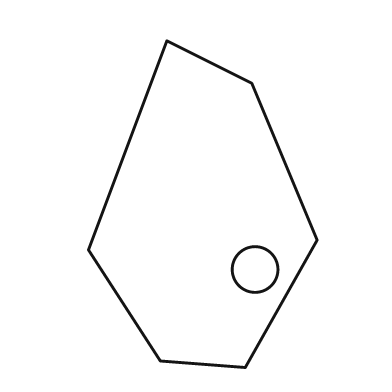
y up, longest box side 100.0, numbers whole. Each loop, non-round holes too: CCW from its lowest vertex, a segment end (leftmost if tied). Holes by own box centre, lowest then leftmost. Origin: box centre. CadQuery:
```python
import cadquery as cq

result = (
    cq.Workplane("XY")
    .moveTo(13.0, -50.0)
    .lineTo(35.0, -11.0)
    .lineTo(15.0, 37.0)
    .lineTo(-11.0, 50.0)
    .lineTo(-35.0, -14.0)
    .lineTo(-13.0, -48.0)
    .close()
    .moveTo(16.0, -20.0)
    .circle(7.0)
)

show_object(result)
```